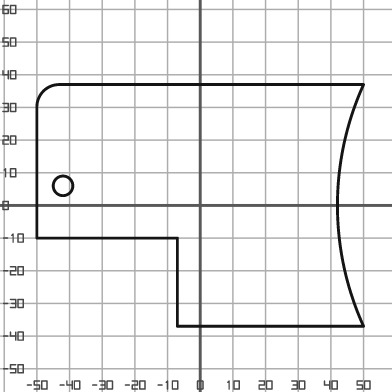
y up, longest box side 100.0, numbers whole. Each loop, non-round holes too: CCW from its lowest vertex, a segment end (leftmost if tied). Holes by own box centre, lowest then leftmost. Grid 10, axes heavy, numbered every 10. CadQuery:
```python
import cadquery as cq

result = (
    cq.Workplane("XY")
    .moveTo(-7.0, -37.0)
    .lineTo(50.0, -37.0)
    .threePointArc((42.0, 0.0), (50.0, 37.0))
    .lineTo(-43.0, 37.0)
    .threePointArc((-48.0, 35.0), (-50.0, 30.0))
    .lineTo(-50.0, -10.0)
    .lineTo(-7.0, -10.0)
    .close()
    .moveTo(-42.0, 6.0)
    .circle(3.0)
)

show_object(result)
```